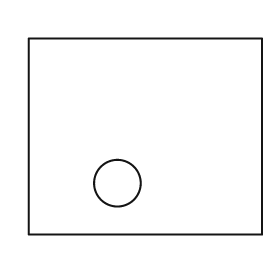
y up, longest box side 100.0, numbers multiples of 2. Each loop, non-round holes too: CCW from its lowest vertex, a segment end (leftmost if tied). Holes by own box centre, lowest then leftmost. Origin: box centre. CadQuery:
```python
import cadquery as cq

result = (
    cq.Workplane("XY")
    .moveTo(-50.0, -42.0)
    .lineTo(50.0, -42.0)
    .lineTo(50.0, 42.0)
    .lineTo(-50.0, 42.0)
    .close()
    .moveTo(-12.0, -20.0)
    .circle(10.0)
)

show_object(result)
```